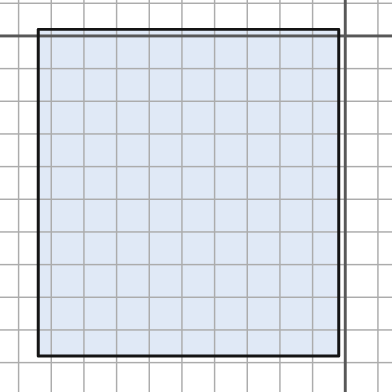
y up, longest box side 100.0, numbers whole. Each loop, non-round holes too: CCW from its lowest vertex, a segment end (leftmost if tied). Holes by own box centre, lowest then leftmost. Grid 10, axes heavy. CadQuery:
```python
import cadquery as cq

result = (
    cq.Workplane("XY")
    .moveTo(-94.0, -98.0)
    .lineTo(-2.0, -98.0)
    .lineTo(-2.0, 2.0)
    .lineTo(-94.0, 2.0)
    .close()
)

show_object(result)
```